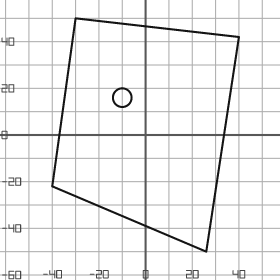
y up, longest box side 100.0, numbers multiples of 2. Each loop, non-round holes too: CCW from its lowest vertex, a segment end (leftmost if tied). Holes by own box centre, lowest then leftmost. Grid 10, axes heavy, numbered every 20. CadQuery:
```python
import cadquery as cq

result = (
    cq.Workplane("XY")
    .moveTo(26.0, -50.0)
    .lineTo(40.0, 42.0)
    .lineTo(-30.0, 50.0)
    .lineTo(-40.0, -22.0)
    .close()
    .moveTo(-10.0, 16.0)
    .circle(4.0)
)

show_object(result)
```